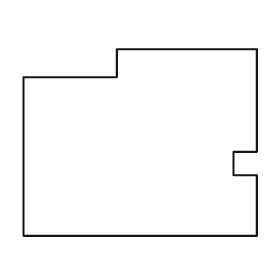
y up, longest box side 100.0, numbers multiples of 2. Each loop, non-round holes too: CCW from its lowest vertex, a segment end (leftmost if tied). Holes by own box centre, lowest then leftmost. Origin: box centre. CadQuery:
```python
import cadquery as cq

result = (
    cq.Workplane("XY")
    .moveTo(-50.0, -40.0)
    .lineTo(50.0, -40.0)
    .lineTo(50.0, -14.0)
    .lineTo(40.0, -14.0)
    .lineTo(40.0, -4.0)
    .lineTo(50.0, -4.0)
    .lineTo(50.0, 40.0)
    .lineTo(-10.0, 40.0)
    .lineTo(-10.0, 28.0)
    .lineTo(-50.0, 28.0)
    .close()
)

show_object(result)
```